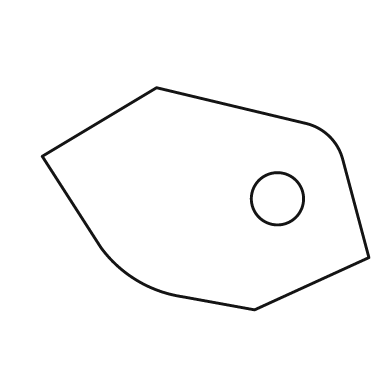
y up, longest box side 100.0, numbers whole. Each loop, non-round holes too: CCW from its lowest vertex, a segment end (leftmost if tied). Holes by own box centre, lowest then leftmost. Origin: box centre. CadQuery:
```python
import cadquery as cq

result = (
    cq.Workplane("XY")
    .moveTo(15.0, -34.0)
    .lineTo(50.0, -18.0)
    .lineTo(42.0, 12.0)
    .threePointArc((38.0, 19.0), (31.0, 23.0))
    .lineTo(-15.0, 34.0)
    .lineTo(-50.0, 13.0)
    .lineTo(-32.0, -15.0)
    .threePointArc((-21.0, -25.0), (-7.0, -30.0))
    .close()
    .moveTo(22.0, 0.0)
    .circle(8.0)
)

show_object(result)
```